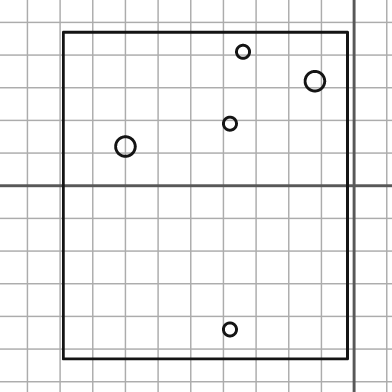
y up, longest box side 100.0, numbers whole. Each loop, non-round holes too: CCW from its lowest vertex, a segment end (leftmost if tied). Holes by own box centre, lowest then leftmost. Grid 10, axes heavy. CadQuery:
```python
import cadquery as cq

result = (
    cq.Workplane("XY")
    .moveTo(-89.0, -53.0)
    .lineTo(-2.0, -53.0)
    .lineTo(-2.0, 47.0)
    .lineTo(-89.0, 47.0)
    .close()
    .moveTo(-38.0, -44.0)
    .circle(2.0)
    .moveTo(-70.0, 12.0)
    .circle(3.0)
    .moveTo(-38.0, 19.0)
    .circle(2.0)
    .moveTo(-12.0, 32.0)
    .circle(3.0)
    .moveTo(-34.0, 41.0)
    .circle(2.0)
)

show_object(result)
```